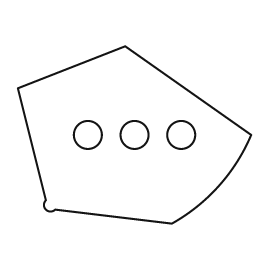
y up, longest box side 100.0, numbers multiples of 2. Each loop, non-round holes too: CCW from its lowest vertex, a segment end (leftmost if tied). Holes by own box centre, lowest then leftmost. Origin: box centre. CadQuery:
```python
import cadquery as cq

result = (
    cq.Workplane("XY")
    .moveTo(16.0, -38.0)
    .threePointArc((36.0, -22.0), (50.0, 0.0))
    .lineTo(-4.0, 38.0)
    .lineTo(-50.0, 20.0)
    .lineTo(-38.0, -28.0)
    .threePointArc((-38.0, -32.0), (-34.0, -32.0))
    .close()
    .moveTo(-20.0, 0.0)
    .circle(6.0)
    .moveTo(0.0, 0.0)
    .circle(6.0)
    .moveTo(20.0, 0.0)
    .circle(6.0)
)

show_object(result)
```